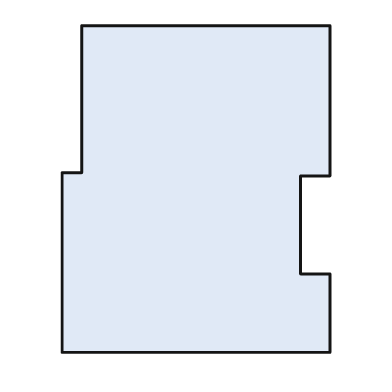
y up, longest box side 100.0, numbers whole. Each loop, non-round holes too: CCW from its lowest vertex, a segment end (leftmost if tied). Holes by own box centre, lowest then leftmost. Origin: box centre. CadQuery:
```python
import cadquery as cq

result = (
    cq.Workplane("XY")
    .moveTo(-41.0, -50.0)
    .lineTo(41.0, -50.0)
    .lineTo(41.0, -26.0)
    .lineTo(32.0, -26.0)
    .lineTo(32.0, 4.0)
    .lineTo(41.0, 4.0)
    .lineTo(41.0, 50.0)
    .lineTo(-35.0, 50.0)
    .lineTo(-35.0, 5.0)
    .lineTo(-41.0, 5.0)
    .close()
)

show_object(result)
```